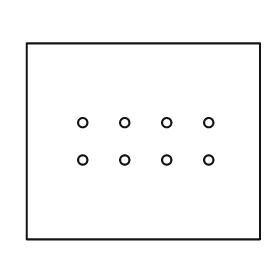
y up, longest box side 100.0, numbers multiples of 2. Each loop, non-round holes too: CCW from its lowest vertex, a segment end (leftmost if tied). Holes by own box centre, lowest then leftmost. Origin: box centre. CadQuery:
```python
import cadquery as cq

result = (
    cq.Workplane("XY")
    .moveTo(-50.0, -42.0)
    .lineTo(50.0, -42.0)
    .lineTo(50.0, 42.0)
    .lineTo(-50.0, 42.0)
    .close()
    .moveTo(-26.0, -8.0)
    .circle(2.0)
    .moveTo(-8.0, -8.0)
    .circle(2.0)
    .moveTo(10.0, -8.0)
    .circle(2.0)
    .moveTo(28.0, -8.0)
    .circle(2.0)
    .moveTo(-26.0, 8.0)
    .circle(2.0)
    .moveTo(-8.0, 8.0)
    .circle(2.0)
    .moveTo(10.0, 8.0)
    .circle(2.0)
    .moveTo(28.0, 8.0)
    .circle(2.0)
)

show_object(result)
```